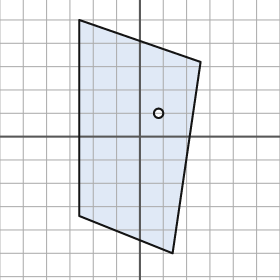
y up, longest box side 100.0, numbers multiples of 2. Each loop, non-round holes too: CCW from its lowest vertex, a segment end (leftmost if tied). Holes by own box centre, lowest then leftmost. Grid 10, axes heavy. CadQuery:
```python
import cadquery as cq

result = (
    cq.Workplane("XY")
    .moveTo(14.0, -50.0)
    .lineTo(26.0, 32.0)
    .lineTo(-26.0, 50.0)
    .lineTo(-26.0, -34.0)
    .close()
    .moveTo(8.0, 10.0)
    .circle(2.0)
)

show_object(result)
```